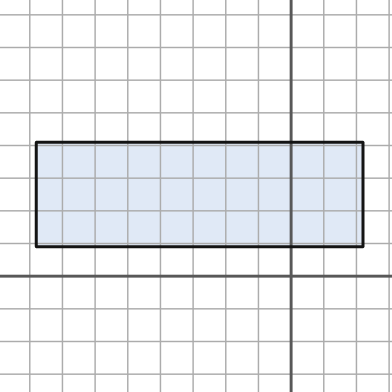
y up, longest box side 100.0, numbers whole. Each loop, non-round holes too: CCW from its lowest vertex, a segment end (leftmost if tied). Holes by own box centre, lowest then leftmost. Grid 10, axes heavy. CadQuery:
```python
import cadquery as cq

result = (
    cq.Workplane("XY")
    .moveTo(-78.0, 9.0)
    .lineTo(22.0, 9.0)
    .lineTo(22.0, 41.0)
    .lineTo(-78.0, 41.0)
    .close()
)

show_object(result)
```